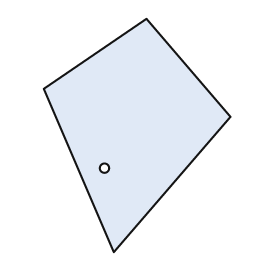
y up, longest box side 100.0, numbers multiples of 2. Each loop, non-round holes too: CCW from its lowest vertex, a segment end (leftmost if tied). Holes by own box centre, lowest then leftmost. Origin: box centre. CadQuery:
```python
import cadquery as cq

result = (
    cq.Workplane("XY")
    .moveTo(-10.0, -50.0)
    .lineTo(40.0, 8.0)
    .lineTo(4.0, 50.0)
    .lineTo(-40.0, 20.0)
    .close()
    .moveTo(-14.0, -14.0)
    .circle(2.0)
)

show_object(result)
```